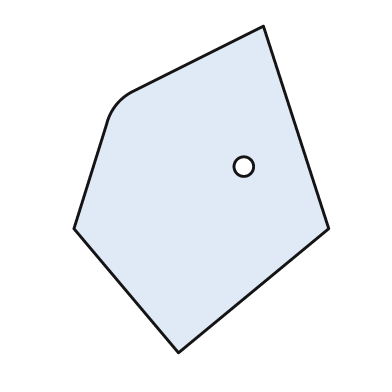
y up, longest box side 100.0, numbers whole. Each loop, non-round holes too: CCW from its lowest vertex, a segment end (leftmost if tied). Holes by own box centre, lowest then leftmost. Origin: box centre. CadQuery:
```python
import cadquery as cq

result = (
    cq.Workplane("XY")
    .moveTo(-7.0, -50.0)
    .lineTo(39.0, -12.0)
    .lineTo(19.0, 50.0)
    .lineTo(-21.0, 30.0)
    .threePointArc((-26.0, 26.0), (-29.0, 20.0))
    .lineTo(-39.0, -12.0)
    .close()
    .moveTo(13.0, 7.0)
    .circle(3.0)
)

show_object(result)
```